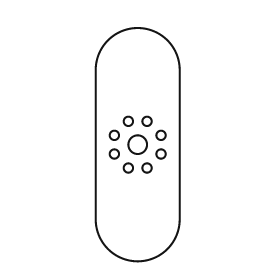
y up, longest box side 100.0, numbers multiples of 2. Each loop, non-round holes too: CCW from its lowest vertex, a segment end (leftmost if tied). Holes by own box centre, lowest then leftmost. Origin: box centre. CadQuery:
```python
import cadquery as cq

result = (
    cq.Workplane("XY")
    .moveTo(-18.0, -32.0)
    .threePointArc((0.0, -50.0), (18.0, -32.0))
    .lineTo(18.0, 32.0)
    .threePointArc((0.0, 50.0), (-18.0, 32.0))
    .close()
    .moveTo(-4.0, -10.0)
    .circle(2.0)
    .moveTo(4.0, -10.0)
    .circle(2.0)
    .moveTo(-10.0, -4.0)
    .circle(2.0)
    .moveTo(10.0, -4.0)
    .circle(2.0)
    .moveTo(0.0, 0.0)
    .circle(4.0)
    .moveTo(-10.0, 4.0)
    .circle(2.0)
    .moveTo(10.0, 4.0)
    .circle(2.0)
    .moveTo(-4.0, 10.0)
    .circle(2.0)
    .moveTo(4.0, 10.0)
    .circle(2.0)
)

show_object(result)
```